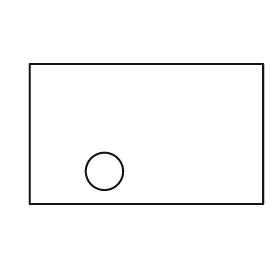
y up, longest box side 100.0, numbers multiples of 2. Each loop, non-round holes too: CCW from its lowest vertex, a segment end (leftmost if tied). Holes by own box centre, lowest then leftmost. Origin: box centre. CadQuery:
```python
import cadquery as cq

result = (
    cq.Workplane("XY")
    .moveTo(-50.0, -30.0)
    .lineTo(50.0, -30.0)
    .lineTo(50.0, 30.0)
    .lineTo(-50.0, 30.0)
    .close()
    .moveTo(-18.0, -16.0)
    .circle(8.0)
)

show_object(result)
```